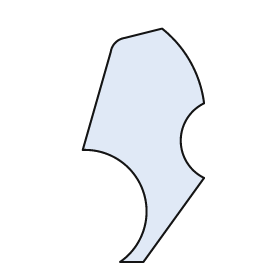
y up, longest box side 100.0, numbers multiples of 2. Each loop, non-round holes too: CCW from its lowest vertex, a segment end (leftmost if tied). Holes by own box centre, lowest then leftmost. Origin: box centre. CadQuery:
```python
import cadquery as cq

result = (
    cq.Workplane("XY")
    .moveTo(-10.0, -50.0)
    .lineTo(0.0, -50.0)
    .lineTo(26.0, -14.0)
    .threePointArc((16.0, 2.0), (26.0, 18.0))
    .threePointArc((20.0, 36.0), (8.0, 50.0))
    .lineTo(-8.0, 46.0)
    .threePointArc((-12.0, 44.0), (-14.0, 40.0))
    .lineTo(-26.0, -2.0)
    .threePointArc((0.0, -20.0), (-10.0, -50.0))
    .close()
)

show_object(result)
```